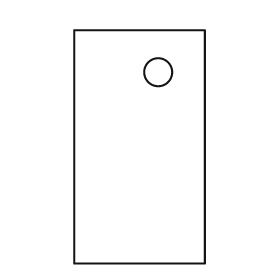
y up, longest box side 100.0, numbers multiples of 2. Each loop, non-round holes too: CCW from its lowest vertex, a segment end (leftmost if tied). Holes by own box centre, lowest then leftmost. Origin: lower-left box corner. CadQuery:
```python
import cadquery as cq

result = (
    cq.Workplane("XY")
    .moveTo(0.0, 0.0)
    .lineTo(56.0, 0.0)
    .lineTo(56.0, 100.0)
    .lineTo(0.0, 100.0)
    .close()
    .moveTo(36.0, 82.0)
    .circle(6.0)
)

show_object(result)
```